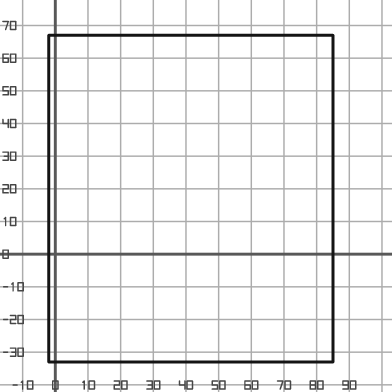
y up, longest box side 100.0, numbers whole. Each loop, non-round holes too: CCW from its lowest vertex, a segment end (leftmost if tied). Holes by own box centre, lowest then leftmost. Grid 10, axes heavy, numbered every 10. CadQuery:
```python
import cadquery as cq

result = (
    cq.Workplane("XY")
    .moveTo(-2.0, -33.0)
    .lineTo(85.0, -33.0)
    .lineTo(85.0, 67.0)
    .lineTo(-2.0, 67.0)
    .close()
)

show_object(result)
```